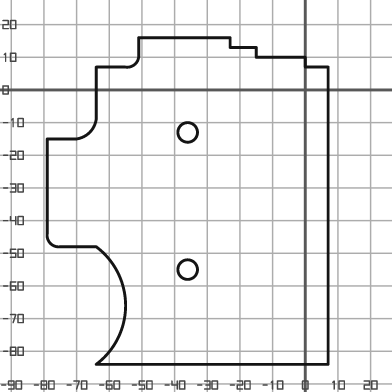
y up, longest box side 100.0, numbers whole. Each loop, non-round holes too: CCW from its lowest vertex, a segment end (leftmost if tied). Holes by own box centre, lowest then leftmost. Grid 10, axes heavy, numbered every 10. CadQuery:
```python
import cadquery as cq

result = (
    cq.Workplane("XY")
    .moveTo(-64.0, -84.0)
    .lineTo(7.0, -84.0)
    .lineTo(7.0, 7.0)
    .lineTo(0.0, 7.0)
    .lineTo(0.0, 10.0)
    .lineTo(-15.0, 10.0)
    .lineTo(-15.0, 13.0)
    .lineTo(-23.0, 13.0)
    .lineTo(-23.0, 16.0)
    .lineTo(-51.0, 16.0)
    .lineTo(-51.0, 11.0)
    .threePointArc((-52.0, 8.0), (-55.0, 7.0))
    .lineTo(-64.0, 7.0)
    .lineTo(-64.0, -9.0)
    .threePointArc((-66.0, -13.0), (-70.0, -15.0))
    .lineTo(-79.0, -15.0)
    .lineTo(-79.0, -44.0)
    .threePointArc((-78.0, -47.0), (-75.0, -48.0))
    .lineTo(-64.0, -48.0)
    .threePointArc((-55.0, -66.0), (-64.0, -84.0))
    .close()
    .moveTo(-36.0, -55.0)
    .circle(3.0)
    .moveTo(-36.0, -13.0)
    .circle(3.0)
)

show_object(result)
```